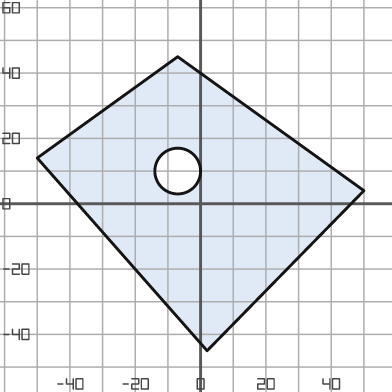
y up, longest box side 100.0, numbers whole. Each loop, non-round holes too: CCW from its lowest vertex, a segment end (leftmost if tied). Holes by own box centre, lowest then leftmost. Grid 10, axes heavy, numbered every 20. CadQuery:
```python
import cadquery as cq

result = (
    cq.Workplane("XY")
    .moveTo(2.0, -45.0)
    .lineTo(50.0, 4.0)
    .lineTo(-7.0, 45.0)
    .lineTo(-50.0, 14.0)
    .close()
    .moveTo(-7.0, 10.0)
    .circle(7.0)
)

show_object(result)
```